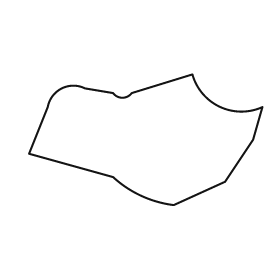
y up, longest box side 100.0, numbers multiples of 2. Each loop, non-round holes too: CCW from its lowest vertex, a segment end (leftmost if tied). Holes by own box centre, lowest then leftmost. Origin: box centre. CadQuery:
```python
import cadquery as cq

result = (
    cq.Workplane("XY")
    .moveTo(12.0, -28.0)
    .lineTo(34.0, -18.0)
    .lineTo(46.0, 0.0)
    .lineTo(50.0, 14.0)
    .threePointArc((32.0, 14.0), (20.0, 28.0))
    .lineTo(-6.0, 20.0)
    .threePointArc((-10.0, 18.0), (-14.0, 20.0))
    .lineTo(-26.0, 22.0)
    .threePointArc((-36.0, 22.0), (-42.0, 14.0))
    .lineTo(-50.0, -6.0)
    .lineTo(-14.0, -16.0)
    .threePointArc((-2.0, -24.0), (12.0, -28.0))
    .close()
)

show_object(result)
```